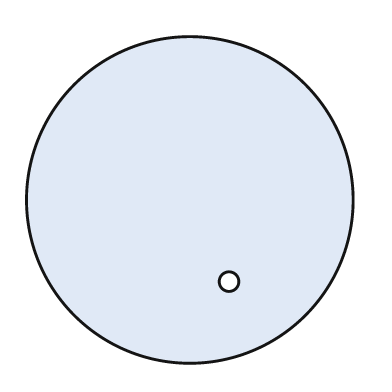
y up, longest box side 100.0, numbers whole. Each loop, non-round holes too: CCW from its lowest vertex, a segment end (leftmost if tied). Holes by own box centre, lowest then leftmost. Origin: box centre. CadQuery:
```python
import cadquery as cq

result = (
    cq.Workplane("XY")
    .moveTo(0.0, 0.0)
    .circle(50.0)
    .moveTo(12.0, -25.0)
    .circle(3.0)
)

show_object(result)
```